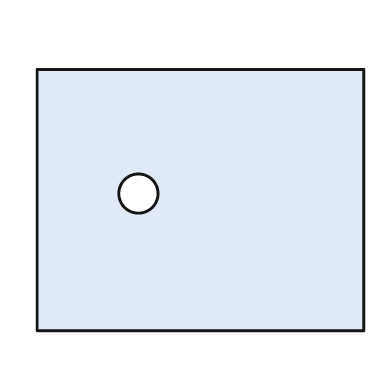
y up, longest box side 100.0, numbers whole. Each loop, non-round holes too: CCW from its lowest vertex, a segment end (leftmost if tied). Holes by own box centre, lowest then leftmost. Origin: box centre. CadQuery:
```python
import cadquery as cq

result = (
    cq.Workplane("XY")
    .moveTo(-50.0, -40.0)
    .lineTo(50.0, -40.0)
    .lineTo(50.0, 40.0)
    .lineTo(-50.0, 40.0)
    .close()
    .moveTo(-19.0, 2.0)
    .circle(6.0)
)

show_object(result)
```